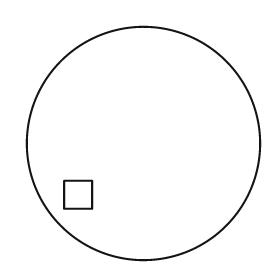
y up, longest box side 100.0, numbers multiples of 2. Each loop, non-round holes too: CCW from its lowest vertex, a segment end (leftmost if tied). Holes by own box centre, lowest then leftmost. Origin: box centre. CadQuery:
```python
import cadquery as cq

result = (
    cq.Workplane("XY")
    .moveTo(0.0, 0.0)
    .circle(50.0)
    .moveTo(-34.0, -28.0)
    .lineTo(-22.0, -28.0)
    .lineTo(-22.0, -16.0)
    .lineTo(-34.0, -16.0)
    .close()
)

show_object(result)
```